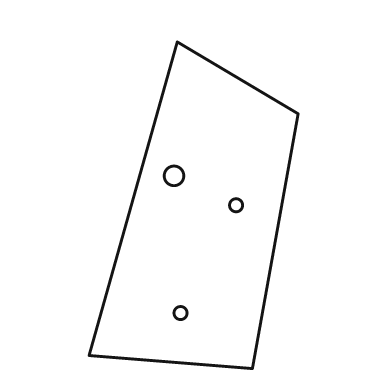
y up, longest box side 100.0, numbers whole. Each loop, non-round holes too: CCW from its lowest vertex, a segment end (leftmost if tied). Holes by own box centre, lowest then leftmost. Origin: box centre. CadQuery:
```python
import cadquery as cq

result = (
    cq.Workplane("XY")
    .moveTo(18.0, -50.0)
    .lineTo(32.0, 28.0)
    .lineTo(-5.0, 50.0)
    .lineTo(-32.0, -46.0)
    .close()
    .moveTo(-4.0, -33.0)
    .circle(2.0)
    .moveTo(13.0, 0.0)
    .circle(2.0)
    .moveTo(-6.0, 9.0)
    .circle(3.0)
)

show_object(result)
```